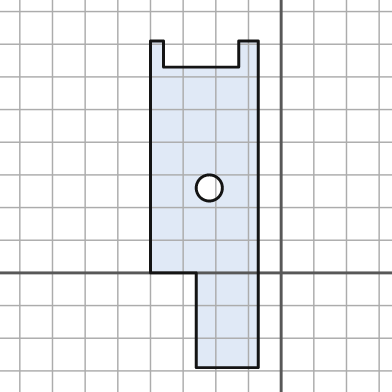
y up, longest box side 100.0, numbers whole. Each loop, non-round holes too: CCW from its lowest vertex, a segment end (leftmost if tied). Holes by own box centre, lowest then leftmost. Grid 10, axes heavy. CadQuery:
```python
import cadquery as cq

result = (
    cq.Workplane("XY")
    .moveTo(-26.0, -29.0)
    .lineTo(-7.0, -29.0)
    .lineTo(-7.0, 71.0)
    .lineTo(-13.0, 71.0)
    .lineTo(-13.0, 63.0)
    .lineTo(-36.0, 63.0)
    .lineTo(-36.0, 71.0)
    .lineTo(-40.0, 71.0)
    .lineTo(-40.0, 0.0)
    .lineTo(-26.0, 0.0)
    .close()
    .moveTo(-22.0, 26.0)
    .circle(4.0)
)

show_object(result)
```